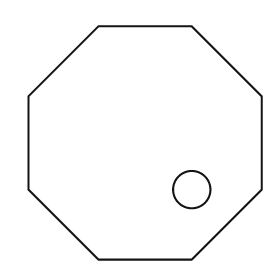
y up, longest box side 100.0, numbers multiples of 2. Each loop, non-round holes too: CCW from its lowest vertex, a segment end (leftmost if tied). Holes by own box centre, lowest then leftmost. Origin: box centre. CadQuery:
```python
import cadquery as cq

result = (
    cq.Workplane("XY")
    .moveTo(-20.0, -50.0)
    .lineTo(20.0, -50.0)
    .lineTo(50.0, -20.0)
    .lineTo(50.0, 20.0)
    .lineTo(20.0, 50.0)
    .lineTo(-20.0, 50.0)
    .lineTo(-50.0, 20.0)
    .lineTo(-50.0, -20.0)
    .close()
    .moveTo(20.0, -20.0)
    .circle(8.0)
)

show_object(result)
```